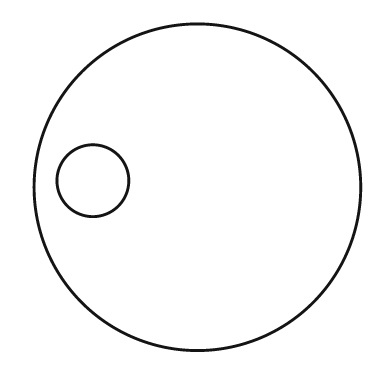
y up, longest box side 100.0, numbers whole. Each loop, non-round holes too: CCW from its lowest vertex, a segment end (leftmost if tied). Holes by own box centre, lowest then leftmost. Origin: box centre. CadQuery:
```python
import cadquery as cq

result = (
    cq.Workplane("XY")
    .moveTo(0.0, 0.0)
    .circle(50.0)
    .moveTo(-32.0, 2.0)
    .circle(11.0)
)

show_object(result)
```